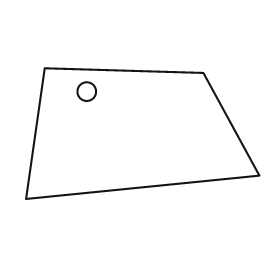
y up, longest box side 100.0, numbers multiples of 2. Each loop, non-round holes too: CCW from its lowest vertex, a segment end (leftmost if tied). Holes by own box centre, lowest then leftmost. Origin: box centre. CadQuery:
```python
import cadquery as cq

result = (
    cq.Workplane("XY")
    .moveTo(-50.0, -28.0)
    .lineTo(50.0, -18.0)
    .lineTo(26.0, 26.0)
    .lineTo(-42.0, 28.0)
    .close()
    .moveTo(-24.0, 18.0)
    .circle(4.0)
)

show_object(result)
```